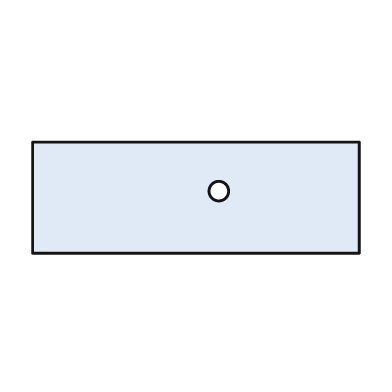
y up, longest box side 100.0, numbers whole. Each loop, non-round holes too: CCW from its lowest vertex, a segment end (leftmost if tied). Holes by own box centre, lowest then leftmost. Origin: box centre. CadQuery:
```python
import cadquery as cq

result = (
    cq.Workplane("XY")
    .moveTo(-50.0, -17.0)
    .lineTo(50.0, -17.0)
    .lineTo(50.0, 17.0)
    .lineTo(-50.0, 17.0)
    .close()
    .moveTo(7.0, 2.0)
    .circle(3.0)
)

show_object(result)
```